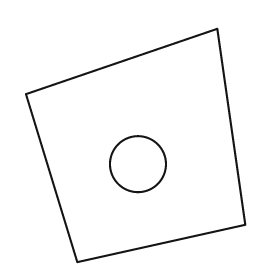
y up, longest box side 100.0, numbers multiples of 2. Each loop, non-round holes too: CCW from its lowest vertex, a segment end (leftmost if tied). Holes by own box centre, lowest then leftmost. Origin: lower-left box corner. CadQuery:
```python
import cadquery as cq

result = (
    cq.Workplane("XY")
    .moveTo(22.0, 0.0)
    .lineTo(94.0, 16.0)
    .lineTo(82.0, 100.0)
    .lineTo(0.0, 72.0)
    .close()
    .moveTo(48.0, 42.0)
    .circle(12.0)
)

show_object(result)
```